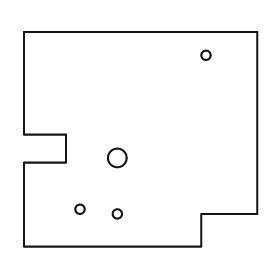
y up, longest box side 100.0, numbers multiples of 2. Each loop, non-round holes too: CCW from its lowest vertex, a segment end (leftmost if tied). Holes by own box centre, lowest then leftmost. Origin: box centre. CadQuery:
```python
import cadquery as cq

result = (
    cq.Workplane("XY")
    .moveTo(-50.0, -46.0)
    .lineTo(26.0, -46.0)
    .lineTo(26.0, -32.0)
    .lineTo(50.0, -32.0)
    .lineTo(50.0, 46.0)
    .lineTo(-50.0, 46.0)
    .lineTo(-50.0, 2.0)
    .lineTo(-32.0, 2.0)
    .lineTo(-32.0, -10.0)
    .lineTo(-50.0, -10.0)
    .close()
    .moveTo(-10.0, -32.0)
    .circle(2.0)
    .moveTo(-26.0, -30.0)
    .circle(2.0)
    .moveTo(-10.0, -8.0)
    .circle(4.0)
    .moveTo(28.0, 36.0)
    .circle(2.0)
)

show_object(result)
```